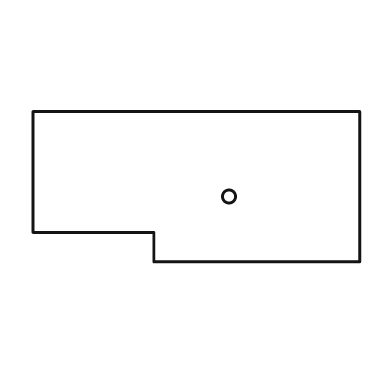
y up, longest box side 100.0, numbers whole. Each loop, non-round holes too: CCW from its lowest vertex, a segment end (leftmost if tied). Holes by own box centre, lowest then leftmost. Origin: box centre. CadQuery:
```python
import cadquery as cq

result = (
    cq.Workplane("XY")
    .moveTo(-13.0, -23.0)
    .lineTo(50.0, -23.0)
    .lineTo(50.0, 23.0)
    .lineTo(-50.0, 23.0)
    .lineTo(-50.0, -14.0)
    .lineTo(-13.0, -14.0)
    .close()
    .moveTo(10.0, -3.0)
    .circle(2.0)
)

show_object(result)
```